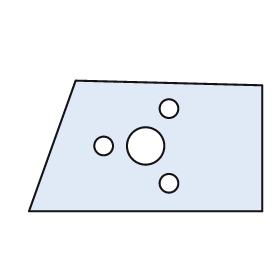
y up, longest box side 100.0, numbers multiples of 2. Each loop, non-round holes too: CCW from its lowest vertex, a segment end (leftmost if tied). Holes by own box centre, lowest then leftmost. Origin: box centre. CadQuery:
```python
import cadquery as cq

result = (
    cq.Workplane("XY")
    .moveTo(-50.0, -28.0)
    .lineTo(50.0, -28.0)
    .lineTo(50.0, 26.0)
    .lineTo(-30.0, 28.0)
    .close()
    .moveTo(10.0, -16.0)
    .circle(4.0)
    .moveTo(-18.0, 0.0)
    .circle(4.0)
    .moveTo(0.0, 0.0)
    .circle(8.0)
    .moveTo(10.0, 16.0)
    .circle(4.0)
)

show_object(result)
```